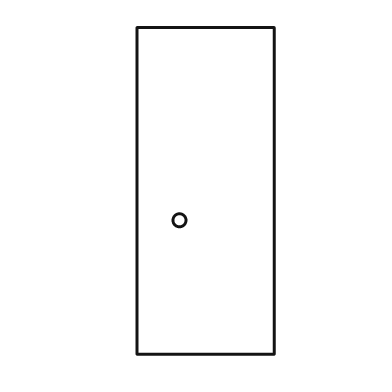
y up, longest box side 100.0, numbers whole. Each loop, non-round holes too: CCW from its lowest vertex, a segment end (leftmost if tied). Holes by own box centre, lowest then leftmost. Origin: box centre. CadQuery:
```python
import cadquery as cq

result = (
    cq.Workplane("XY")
    .moveTo(-21.0, -50.0)
    .lineTo(21.0, -50.0)
    .lineTo(21.0, 50.0)
    .lineTo(-21.0, 50.0)
    .close()
    .moveTo(-8.0, -9.0)
    .circle(2.0)
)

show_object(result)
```